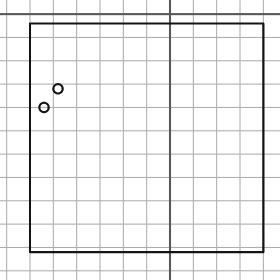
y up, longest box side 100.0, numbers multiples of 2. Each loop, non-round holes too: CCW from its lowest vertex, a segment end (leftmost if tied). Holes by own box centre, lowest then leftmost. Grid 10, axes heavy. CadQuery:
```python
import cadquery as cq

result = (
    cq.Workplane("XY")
    .moveTo(-60.0, -102.0)
    .lineTo(40.0, -102.0)
    .lineTo(40.0, -4.0)
    .lineTo(-60.0, -4.0)
    .close()
    .moveTo(-54.0, -40.0)
    .circle(2.0)
    .moveTo(-48.0, -32.0)
    .circle(2.0)
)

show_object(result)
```